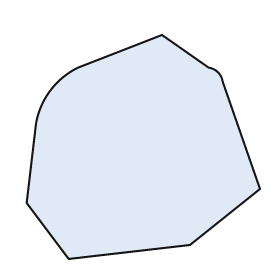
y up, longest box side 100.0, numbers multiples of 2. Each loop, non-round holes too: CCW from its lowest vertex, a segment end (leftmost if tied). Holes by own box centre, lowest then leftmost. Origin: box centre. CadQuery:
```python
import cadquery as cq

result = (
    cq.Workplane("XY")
    .moveTo(-32.0, -48.0)
    .lineTo(20.0, -42.0)
    .lineTo(50.0, -18.0)
    .lineTo(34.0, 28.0)
    .threePointArc((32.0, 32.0), (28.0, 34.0))
    .lineTo(8.0, 48.0)
    .lineTo(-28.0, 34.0)
    .threePointArc((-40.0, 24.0), (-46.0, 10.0))
    .lineTo(-50.0, -24.0)
    .close()
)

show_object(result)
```